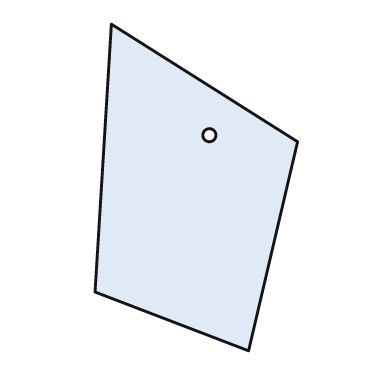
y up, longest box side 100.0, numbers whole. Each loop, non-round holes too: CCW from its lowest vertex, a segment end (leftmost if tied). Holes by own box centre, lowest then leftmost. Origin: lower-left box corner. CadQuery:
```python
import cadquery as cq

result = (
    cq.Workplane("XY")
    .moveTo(47.0, 0.0)
    .lineTo(62.0, 64.0)
    .lineTo(5.0, 100.0)
    .lineTo(0.0, 18.0)
    .close()
    .moveTo(35.0, 66.0)
    .circle(2.0)
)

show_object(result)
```